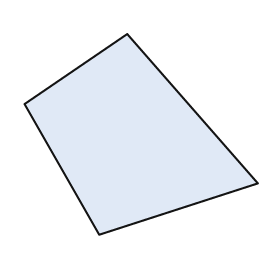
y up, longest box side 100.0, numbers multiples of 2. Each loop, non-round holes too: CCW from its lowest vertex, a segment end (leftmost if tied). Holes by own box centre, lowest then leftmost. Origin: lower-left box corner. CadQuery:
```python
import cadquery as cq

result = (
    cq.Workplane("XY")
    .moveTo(32.0, 0.0)
    .lineTo(100.0, 22.0)
    .lineTo(44.0, 86.0)
    .lineTo(0.0, 56.0)
    .close()
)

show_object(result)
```